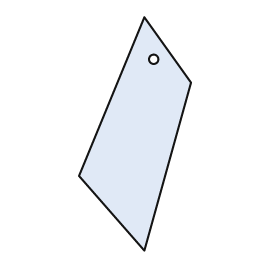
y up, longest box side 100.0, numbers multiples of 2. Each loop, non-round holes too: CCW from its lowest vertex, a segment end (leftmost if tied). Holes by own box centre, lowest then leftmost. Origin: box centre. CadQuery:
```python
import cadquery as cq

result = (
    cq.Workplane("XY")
    .moveTo(4.0, -50.0)
    .lineTo(24.0, 22.0)
    .lineTo(4.0, 50.0)
    .lineTo(-24.0, -18.0)
    .close()
    .moveTo(8.0, 32.0)
    .circle(2.0)
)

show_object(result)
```